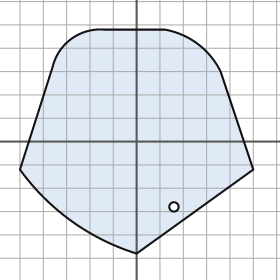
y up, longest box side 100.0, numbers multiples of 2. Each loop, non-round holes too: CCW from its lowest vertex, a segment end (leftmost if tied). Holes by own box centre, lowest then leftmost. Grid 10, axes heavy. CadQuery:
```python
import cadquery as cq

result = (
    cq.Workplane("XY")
    .moveTo(0.0, -48.0)
    .lineTo(50.0, -12.0)
    .lineTo(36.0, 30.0)
    .threePointArc((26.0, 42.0), (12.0, 48.0))
    .lineTo(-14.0, 48.0)
    .threePointArc((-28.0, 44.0), (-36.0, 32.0))
    .lineTo(-50.0, -12.0)
    .threePointArc((-28.0, -34.0), (0.0, -48.0))
    .close()
    .moveTo(16.0, -28.0)
    .circle(2.0)
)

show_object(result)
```